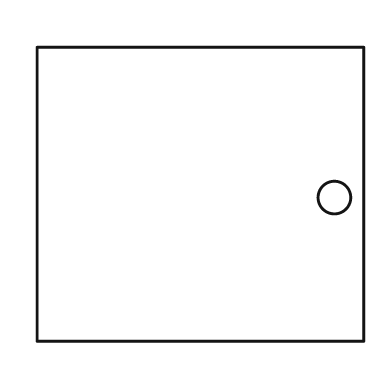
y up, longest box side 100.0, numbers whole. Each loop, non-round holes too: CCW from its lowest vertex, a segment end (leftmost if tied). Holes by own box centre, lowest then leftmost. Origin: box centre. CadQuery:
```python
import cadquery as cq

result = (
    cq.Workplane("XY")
    .moveTo(-50.0, -45.0)
    .lineTo(50.0, -45.0)
    .lineTo(50.0, 45.0)
    .lineTo(-50.0, 45.0)
    .close()
    .moveTo(41.0, -1.0)
    .circle(5.0)
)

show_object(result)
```